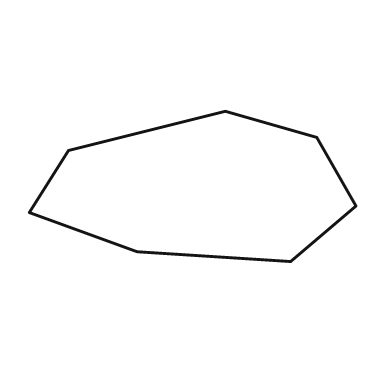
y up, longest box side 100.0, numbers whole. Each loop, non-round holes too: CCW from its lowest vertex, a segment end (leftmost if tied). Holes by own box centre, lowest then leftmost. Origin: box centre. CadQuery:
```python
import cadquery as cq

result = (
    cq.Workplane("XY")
    .moveTo(30.0, -23.0)
    .lineTo(50.0, -6.0)
    .lineTo(38.0, 15.0)
    .lineTo(10.0, 23.0)
    .lineTo(-38.0, 11.0)
    .lineTo(-50.0, -8.0)
    .lineTo(-17.0, -20.0)
    .close()
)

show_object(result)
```